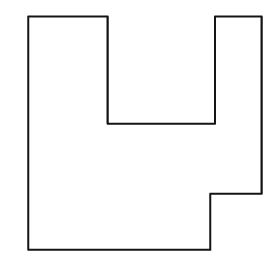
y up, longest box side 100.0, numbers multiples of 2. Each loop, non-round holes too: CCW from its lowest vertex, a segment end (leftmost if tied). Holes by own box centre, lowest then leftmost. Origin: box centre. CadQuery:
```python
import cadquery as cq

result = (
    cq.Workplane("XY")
    .moveTo(-50.0, -50.0)
    .lineTo(28.0, -50.0)
    .lineTo(28.0, -26.0)
    .lineTo(50.0, -26.0)
    .lineTo(50.0, 50.0)
    .lineTo(30.0, 50.0)
    .lineTo(30.0, 4.0)
    .lineTo(-16.0, 4.0)
    .lineTo(-16.0, 50.0)
    .lineTo(-50.0, 50.0)
    .close()
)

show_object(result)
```